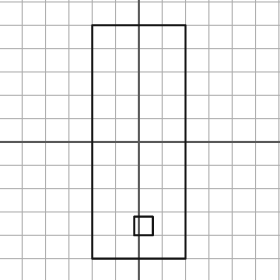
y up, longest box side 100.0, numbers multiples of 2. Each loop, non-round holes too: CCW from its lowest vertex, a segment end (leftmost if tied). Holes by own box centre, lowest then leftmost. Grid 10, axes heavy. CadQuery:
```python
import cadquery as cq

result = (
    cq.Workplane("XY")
    .moveTo(-20.0, -50.0)
    .lineTo(20.0, -50.0)
    .lineTo(20.0, 50.0)
    .lineTo(-20.0, 50.0)
    .close()
    .moveTo(-2.0, -40.0)
    .lineTo(6.0, -40.0)
    .lineTo(6.0, -32.0)
    .lineTo(-2.0, -32.0)
    .close()
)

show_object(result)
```